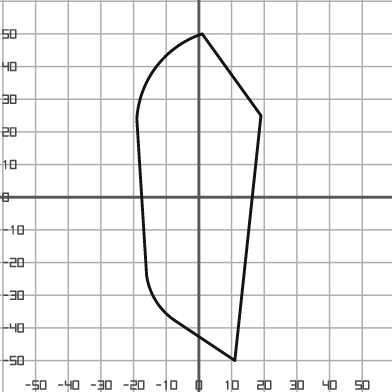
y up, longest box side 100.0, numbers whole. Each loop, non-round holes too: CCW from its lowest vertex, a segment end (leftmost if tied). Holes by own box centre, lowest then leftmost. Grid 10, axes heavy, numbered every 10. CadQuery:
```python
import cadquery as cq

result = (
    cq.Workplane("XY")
    .moveTo(11.0, -50.0)
    .lineTo(19.0, 25.0)
    .lineTo(1.0, 50.0)
    .threePointArc((-13.0, 40.0), (-19.0, 24.0))
    .lineTo(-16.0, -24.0)
    .threePointArc((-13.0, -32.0), (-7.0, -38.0))
    .close()
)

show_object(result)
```